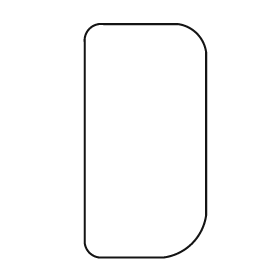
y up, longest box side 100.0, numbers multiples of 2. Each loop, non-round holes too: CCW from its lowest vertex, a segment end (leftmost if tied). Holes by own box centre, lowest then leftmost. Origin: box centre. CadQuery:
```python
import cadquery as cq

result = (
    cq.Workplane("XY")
    .moveTo(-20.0, -50.0)
    .lineTo(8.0, -50.0)
    .threePointArc((20.0, -44.0), (26.0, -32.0))
    .lineTo(26.0, 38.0)
    .threePointArc((22.0, 46.0), (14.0, 50.0))
    .lineTo(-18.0, 50.0)
    .threePointArc((-24.0, 48.0), (-26.0, 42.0))
    .lineTo(-26.0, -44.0)
    .threePointArc((-24.0, -48.0), (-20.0, -50.0))
    .close()
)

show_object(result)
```